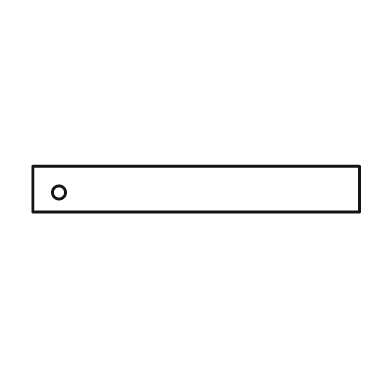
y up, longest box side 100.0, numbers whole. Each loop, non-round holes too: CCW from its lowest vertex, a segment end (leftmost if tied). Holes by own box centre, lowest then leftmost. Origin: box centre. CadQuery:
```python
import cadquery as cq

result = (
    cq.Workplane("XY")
    .moveTo(-50.0, -7.0)
    .lineTo(50.0, -7.0)
    .lineTo(50.0, 7.0)
    .lineTo(-50.0, 7.0)
    .close()
    .moveTo(-42.0, -1.0)
    .circle(2.0)
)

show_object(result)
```